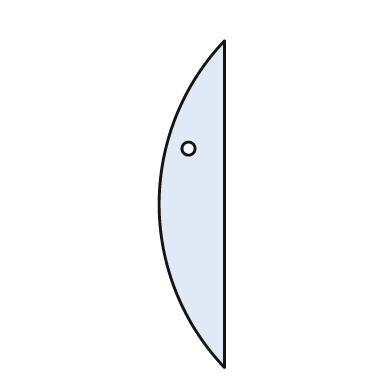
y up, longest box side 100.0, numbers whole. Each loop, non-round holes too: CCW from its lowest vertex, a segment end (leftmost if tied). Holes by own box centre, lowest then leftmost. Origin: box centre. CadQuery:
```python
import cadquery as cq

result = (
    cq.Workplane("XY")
    .moveTo(10.0, -50.0)
    .lineTo(10.0, 50.0)
    .threePointArc((-10.0, 0.0), (10.0, -50.0))
    .close()
    .moveTo(-1.0, 17.0)
    .circle(2.0)
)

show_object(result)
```